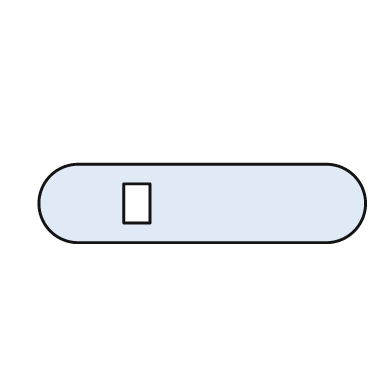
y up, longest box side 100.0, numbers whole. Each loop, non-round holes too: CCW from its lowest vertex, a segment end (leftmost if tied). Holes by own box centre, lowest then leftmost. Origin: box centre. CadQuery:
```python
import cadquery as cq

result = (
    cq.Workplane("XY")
    .moveTo(-38.0, -12.0)
    .lineTo(38.0, -12.0)
    .threePointArc((50.0, 0.0), (38.0, 12.0))
    .lineTo(-38.0, 12.0)
    .threePointArc((-50.0, 0.0), (-38.0, -12.0))
    .close()
    .moveTo(-24.0, -6.0)
    .lineTo(-16.0, -6.0)
    .lineTo(-16.0, 6.0)
    .lineTo(-24.0, 6.0)
    .close()
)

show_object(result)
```